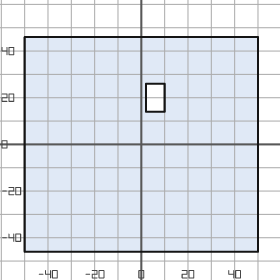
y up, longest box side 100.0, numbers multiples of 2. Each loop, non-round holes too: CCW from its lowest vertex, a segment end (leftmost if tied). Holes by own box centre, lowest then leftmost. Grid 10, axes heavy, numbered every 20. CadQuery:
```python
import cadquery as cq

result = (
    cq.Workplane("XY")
    .moveTo(-50.0, -46.0)
    .lineTo(50.0, -46.0)
    .lineTo(50.0, 46.0)
    .lineTo(-50.0, 46.0)
    .close()
    .moveTo(2.0, 14.0)
    .lineTo(10.0, 14.0)
    .lineTo(10.0, 26.0)
    .lineTo(2.0, 26.0)
    .close()
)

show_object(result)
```